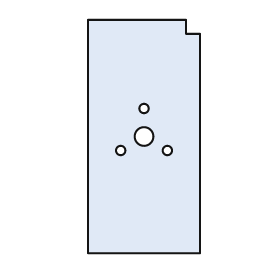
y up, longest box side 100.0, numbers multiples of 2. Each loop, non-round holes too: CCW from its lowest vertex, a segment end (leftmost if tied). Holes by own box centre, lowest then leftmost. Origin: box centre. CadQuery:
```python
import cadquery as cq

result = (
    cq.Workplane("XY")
    .moveTo(-24.0, -50.0)
    .lineTo(24.0, -50.0)
    .lineTo(24.0, 44.0)
    .lineTo(18.0, 44.0)
    .lineTo(18.0, 50.0)
    .lineTo(-24.0, 50.0)
    .close()
    .moveTo(-10.0, -6.0)
    .circle(2.0)
    .moveTo(10.0, -6.0)
    .circle(2.0)
    .moveTo(0.0, 0.0)
    .circle(4.0)
    .moveTo(0.0, 12.0)
    .circle(2.0)
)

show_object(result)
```